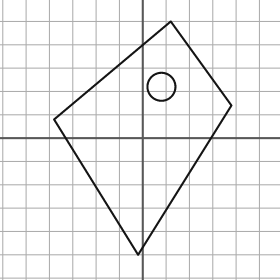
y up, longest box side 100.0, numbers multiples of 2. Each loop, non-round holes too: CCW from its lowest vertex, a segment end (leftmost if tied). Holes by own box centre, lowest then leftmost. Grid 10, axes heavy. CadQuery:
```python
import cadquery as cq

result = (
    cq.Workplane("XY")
    .moveTo(-2.0, -50.0)
    .lineTo(38.0, 14.0)
    .lineTo(12.0, 50.0)
    .lineTo(-38.0, 8.0)
    .close()
    .moveTo(8.0, 22.0)
    .circle(6.0)
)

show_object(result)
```